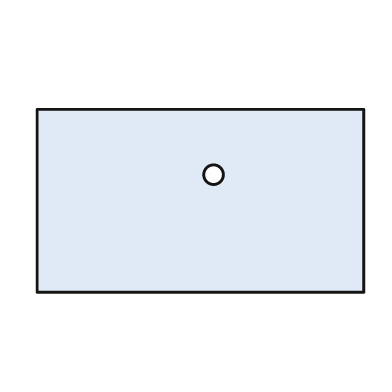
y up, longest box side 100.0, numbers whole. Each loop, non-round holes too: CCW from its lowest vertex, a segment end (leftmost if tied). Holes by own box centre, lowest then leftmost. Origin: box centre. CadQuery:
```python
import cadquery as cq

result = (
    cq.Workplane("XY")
    .moveTo(-50.0, -28.0)
    .lineTo(50.0, -28.0)
    .lineTo(50.0, 28.0)
    .lineTo(-50.0, 28.0)
    .close()
    .moveTo(4.0, 8.0)
    .circle(3.0)
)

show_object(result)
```